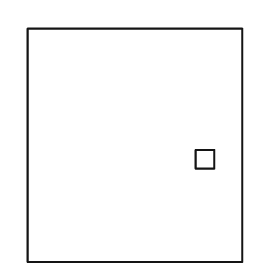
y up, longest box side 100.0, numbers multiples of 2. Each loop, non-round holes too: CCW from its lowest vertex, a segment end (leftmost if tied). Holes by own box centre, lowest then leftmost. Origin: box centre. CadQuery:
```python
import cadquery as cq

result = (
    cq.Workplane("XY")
    .moveTo(-46.0, -50.0)
    .lineTo(46.0, -50.0)
    .lineTo(46.0, 50.0)
    .lineTo(-46.0, 50.0)
    .close()
    .moveTo(26.0, -10.0)
    .lineTo(34.0, -10.0)
    .lineTo(34.0, -2.0)
    .lineTo(26.0, -2.0)
    .close()
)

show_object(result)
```